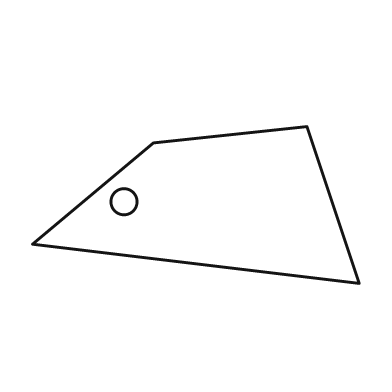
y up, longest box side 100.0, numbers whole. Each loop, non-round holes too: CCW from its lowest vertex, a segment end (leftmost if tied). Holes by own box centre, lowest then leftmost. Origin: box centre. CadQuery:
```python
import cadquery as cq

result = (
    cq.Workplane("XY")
    .moveTo(50.0, -24.0)
    .lineTo(34.0, 24.0)
    .lineTo(-13.0, 19.0)
    .lineTo(-50.0, -12.0)
    .close()
    .moveTo(-22.0, 1.0)
    .circle(4.0)
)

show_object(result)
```